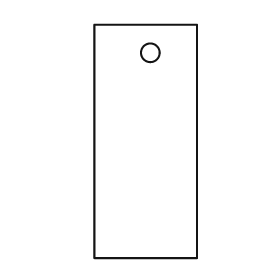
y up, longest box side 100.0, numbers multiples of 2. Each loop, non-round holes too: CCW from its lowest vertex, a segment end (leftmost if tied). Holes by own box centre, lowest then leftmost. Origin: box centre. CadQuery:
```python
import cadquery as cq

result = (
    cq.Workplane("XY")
    .moveTo(-22.0, -50.0)
    .lineTo(22.0, -50.0)
    .lineTo(22.0, 50.0)
    .lineTo(-22.0, 50.0)
    .close()
    .moveTo(2.0, 38.0)
    .circle(4.0)
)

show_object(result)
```